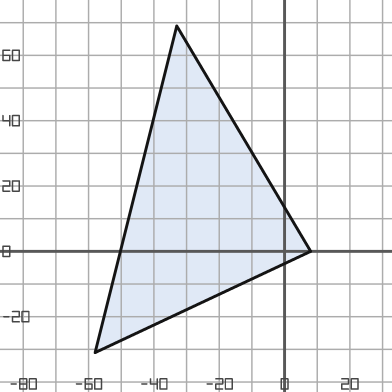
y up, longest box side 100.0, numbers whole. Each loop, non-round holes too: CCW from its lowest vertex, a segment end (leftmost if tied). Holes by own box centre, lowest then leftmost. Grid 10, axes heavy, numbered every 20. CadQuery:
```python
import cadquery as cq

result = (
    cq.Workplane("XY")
    .moveTo(-58.0, -31.0)
    .lineTo(8.0, 0.0)
    .lineTo(-33.0, 69.0)
    .close()
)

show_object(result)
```